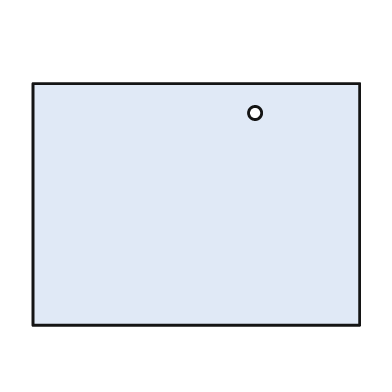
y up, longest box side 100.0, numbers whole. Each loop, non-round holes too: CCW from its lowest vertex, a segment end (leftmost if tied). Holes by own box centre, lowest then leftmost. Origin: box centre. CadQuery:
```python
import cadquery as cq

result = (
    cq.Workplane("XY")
    .moveTo(-50.0, -37.0)
    .lineTo(50.0, -37.0)
    .lineTo(50.0, 37.0)
    .lineTo(-50.0, 37.0)
    .close()
    .moveTo(18.0, 28.0)
    .circle(2.0)
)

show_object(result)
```